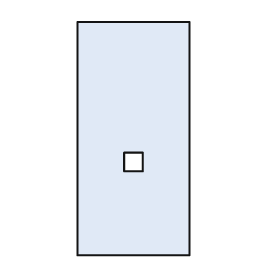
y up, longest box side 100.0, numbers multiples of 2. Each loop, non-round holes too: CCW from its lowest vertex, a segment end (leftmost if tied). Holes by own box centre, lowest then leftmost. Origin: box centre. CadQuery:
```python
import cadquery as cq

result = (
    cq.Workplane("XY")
    .moveTo(-24.0, -50.0)
    .lineTo(24.0, -50.0)
    .lineTo(24.0, 50.0)
    .lineTo(-24.0, 50.0)
    .close()
    .moveTo(-4.0, -14.0)
    .lineTo(4.0, -14.0)
    .lineTo(4.0, -6.0)
    .lineTo(-4.0, -6.0)
    .close()
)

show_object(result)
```